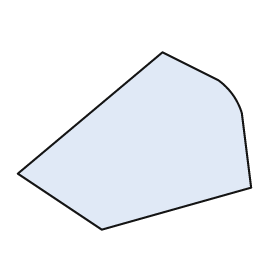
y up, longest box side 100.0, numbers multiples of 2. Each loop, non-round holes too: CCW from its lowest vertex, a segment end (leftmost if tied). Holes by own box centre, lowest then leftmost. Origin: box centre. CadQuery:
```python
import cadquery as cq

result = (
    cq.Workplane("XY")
    .moveTo(-14.0, -38.0)
    .lineTo(50.0, -20.0)
    .lineTo(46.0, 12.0)
    .threePointArc((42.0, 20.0), (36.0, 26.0))
    .lineTo(12.0, 38.0)
    .lineTo(-50.0, -14.0)
    .close()
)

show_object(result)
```